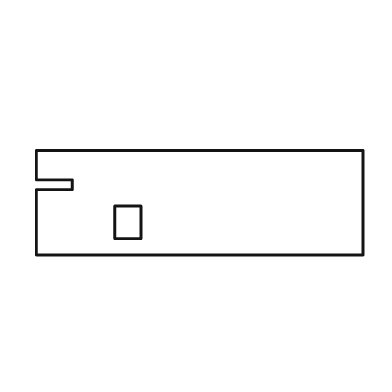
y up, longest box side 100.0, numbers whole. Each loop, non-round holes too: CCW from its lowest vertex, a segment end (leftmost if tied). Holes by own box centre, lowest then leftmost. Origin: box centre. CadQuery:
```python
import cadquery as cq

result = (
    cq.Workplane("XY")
    .moveTo(-50.0, -16.0)
    .lineTo(50.0, -16.0)
    .lineTo(50.0, 16.0)
    .lineTo(-50.0, 16.0)
    .lineTo(-50.0, 7.0)
    .lineTo(-39.0, 7.0)
    .lineTo(-39.0, 4.0)
    .lineTo(-50.0, 4.0)
    .close()
    .moveTo(-26.0, -11.0)
    .lineTo(-18.0, -11.0)
    .lineTo(-18.0, -1.0)
    .lineTo(-26.0, -1.0)
    .close()
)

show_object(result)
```